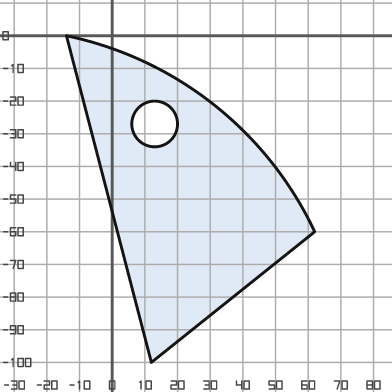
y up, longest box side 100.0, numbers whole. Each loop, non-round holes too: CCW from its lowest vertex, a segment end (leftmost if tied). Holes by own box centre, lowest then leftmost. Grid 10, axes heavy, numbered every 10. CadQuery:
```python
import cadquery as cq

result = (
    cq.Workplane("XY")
    .moveTo(12.0, -100.0)
    .lineTo(62.0, -60.0)
    .threePointArc((31.0, -21.0), (-14.0, 0.0))
    .close()
    .moveTo(13.0, -27.0)
    .circle(7.0)
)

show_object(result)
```